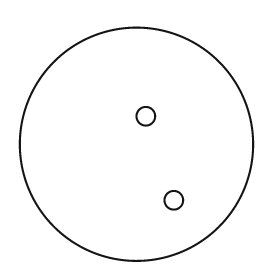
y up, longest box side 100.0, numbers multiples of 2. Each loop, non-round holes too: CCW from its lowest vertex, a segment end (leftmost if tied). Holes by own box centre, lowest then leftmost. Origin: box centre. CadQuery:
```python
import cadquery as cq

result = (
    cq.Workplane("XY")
    .moveTo(0.0, 0.0)
    .circle(50.0)
    .moveTo(16.0, -24.0)
    .circle(4.0)
    .moveTo(4.0, 12.0)
    .circle(4.0)
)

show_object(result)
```